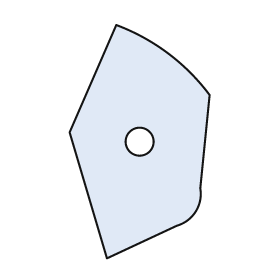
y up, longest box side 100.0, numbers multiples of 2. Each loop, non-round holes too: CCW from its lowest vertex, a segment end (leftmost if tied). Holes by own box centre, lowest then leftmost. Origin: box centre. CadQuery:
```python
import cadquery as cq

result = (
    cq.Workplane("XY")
    .moveTo(-14.0, -50.0)
    .lineTo(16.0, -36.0)
    .threePointArc((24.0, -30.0), (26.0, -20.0))
    .lineTo(30.0, 20.0)
    .threePointArc((12.0, 38.0), (-10.0, 50.0))
    .lineTo(-30.0, 4.0)
    .close()
    .moveTo(0.0, 0.0)
    .circle(6.0)
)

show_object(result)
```